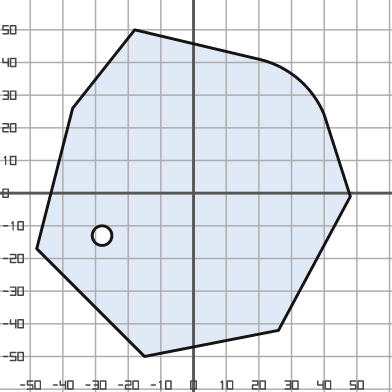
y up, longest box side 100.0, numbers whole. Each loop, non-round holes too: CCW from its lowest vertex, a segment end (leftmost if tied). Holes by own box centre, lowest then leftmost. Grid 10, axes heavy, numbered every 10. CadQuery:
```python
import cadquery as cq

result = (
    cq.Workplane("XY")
    .moveTo(-15.0, -50.0)
    .lineTo(26.0, -42.0)
    .lineTo(48.0, -1.0)
    .lineTo(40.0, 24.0)
    .threePointArc((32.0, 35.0), (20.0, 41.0))
    .lineTo(-18.0, 50.0)
    .lineTo(-37.0, 26.0)
    .lineTo(-48.0, -17.0)
    .close()
    .moveTo(-28.0, -13.0)
    .circle(3.0)
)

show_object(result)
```